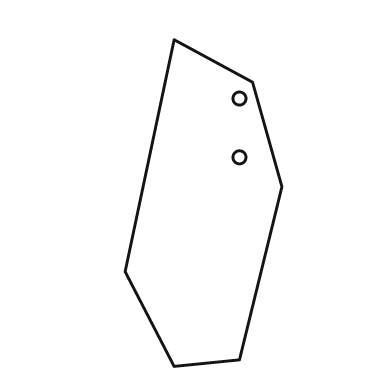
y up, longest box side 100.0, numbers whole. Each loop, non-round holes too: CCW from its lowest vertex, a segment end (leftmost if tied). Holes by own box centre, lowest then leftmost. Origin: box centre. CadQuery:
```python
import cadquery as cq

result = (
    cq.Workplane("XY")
    .moveTo(-9.0, -50.0)
    .lineTo(11.0, -48.0)
    .lineTo(24.0, 5.0)
    .lineTo(15.0, 37.0)
    .lineTo(-9.0, 50.0)
    .lineTo(-24.0, -21.0)
    .close()
    .moveTo(11.0, 14.0)
    .circle(2.0)
    .moveTo(11.0, 32.0)
    .circle(2.0)
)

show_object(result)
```